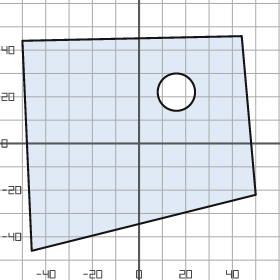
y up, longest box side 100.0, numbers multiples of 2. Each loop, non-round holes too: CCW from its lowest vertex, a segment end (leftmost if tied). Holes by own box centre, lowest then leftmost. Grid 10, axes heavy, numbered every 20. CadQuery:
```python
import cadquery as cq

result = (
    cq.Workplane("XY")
    .moveTo(-46.0, -46.0)
    .lineTo(50.0, -22.0)
    .lineTo(44.0, 46.0)
    .lineTo(-50.0, 44.0)
    .close()
    .moveTo(16.0, 22.0)
    .circle(8.0)
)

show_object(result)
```